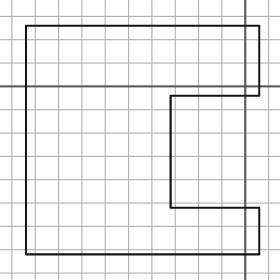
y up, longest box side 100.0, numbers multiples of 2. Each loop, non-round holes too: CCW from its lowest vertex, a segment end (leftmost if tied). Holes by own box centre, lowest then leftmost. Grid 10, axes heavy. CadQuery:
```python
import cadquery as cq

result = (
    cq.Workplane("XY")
    .moveTo(-94.0, -72.0)
    .lineTo(6.0, -72.0)
    .lineTo(6.0, -52.0)
    .lineTo(-32.0, -52.0)
    .lineTo(-32.0, -4.0)
    .lineTo(6.0, -4.0)
    .lineTo(6.0, 26.0)
    .lineTo(-94.0, 26.0)
    .close()
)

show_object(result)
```